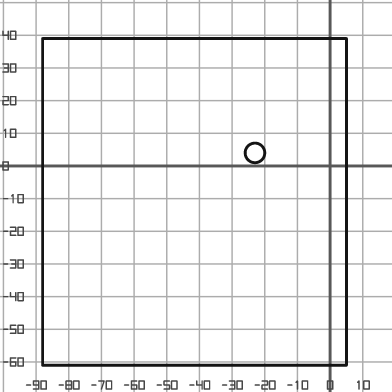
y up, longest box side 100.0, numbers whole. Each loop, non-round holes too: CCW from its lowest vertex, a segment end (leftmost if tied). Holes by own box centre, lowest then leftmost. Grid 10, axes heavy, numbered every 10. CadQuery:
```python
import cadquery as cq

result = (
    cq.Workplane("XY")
    .moveTo(-88.0, -61.0)
    .lineTo(5.0, -61.0)
    .lineTo(5.0, 39.0)
    .lineTo(-88.0, 39.0)
    .close()
    .moveTo(-23.0, 4.0)
    .circle(3.0)
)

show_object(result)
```